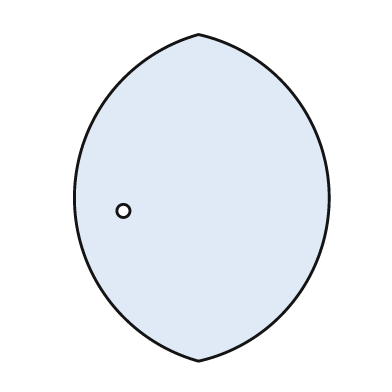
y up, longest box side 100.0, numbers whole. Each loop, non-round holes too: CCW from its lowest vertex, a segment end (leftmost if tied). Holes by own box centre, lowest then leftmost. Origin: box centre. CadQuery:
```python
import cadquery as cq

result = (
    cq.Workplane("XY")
    .moveTo(-1.0, -50.0)
    .threePointArc((39.0, 0.0), (-1.0, 50.0))
    .threePointArc((-39.0, 0.0), (-1.0, -50.0))
    .close()
    .moveTo(-24.0, -4.0)
    .circle(2.0)
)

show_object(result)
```